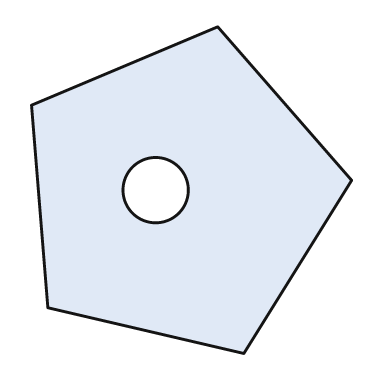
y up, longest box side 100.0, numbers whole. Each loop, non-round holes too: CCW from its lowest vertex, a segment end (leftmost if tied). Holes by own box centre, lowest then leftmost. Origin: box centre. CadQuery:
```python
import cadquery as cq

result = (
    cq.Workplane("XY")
    .moveTo(16.0, -50.0)
    .lineTo(49.0, 3.0)
    .lineTo(8.0, 50.0)
    .lineTo(-49.0, 26.0)
    .lineTo(-44.0, -36.0)
    .close()
    .moveTo(-11.0, 0.0)
    .circle(10.0)
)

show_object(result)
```